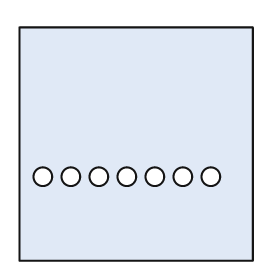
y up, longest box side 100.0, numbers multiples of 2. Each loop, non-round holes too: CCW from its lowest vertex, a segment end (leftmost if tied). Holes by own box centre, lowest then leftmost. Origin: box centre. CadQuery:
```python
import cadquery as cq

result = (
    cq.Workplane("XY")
    .moveTo(-50.0, -50.0)
    .lineTo(50.0, -50.0)
    .lineTo(50.0, 50.0)
    .lineTo(-50.0, 50.0)
    .close()
    .moveTo(-40.0, -14.0)
    .circle(4.0)
    .moveTo(-28.0, -14.0)
    .circle(4.0)
    .moveTo(-16.0, -14.0)
    .circle(4.0)
    .moveTo(-4.0, -14.0)
    .circle(4.0)
    .moveTo(8.0, -14.0)
    .circle(4.0)
    .moveTo(20.0, -14.0)
    .circle(4.0)
    .moveTo(32.0, -14.0)
    .circle(4.0)
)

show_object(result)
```